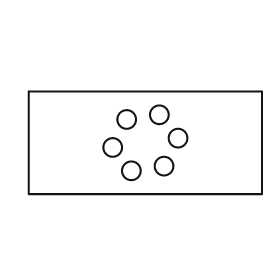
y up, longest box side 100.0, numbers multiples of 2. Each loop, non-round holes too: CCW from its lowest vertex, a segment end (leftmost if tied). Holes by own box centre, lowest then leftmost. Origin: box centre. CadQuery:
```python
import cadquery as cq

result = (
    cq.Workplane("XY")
    .moveTo(-50.0, -22.0)
    .lineTo(50.0, -22.0)
    .lineTo(50.0, 22.0)
    .lineTo(-50.0, 22.0)
    .close()
    .moveTo(-6.0, -12.0)
    .circle(4.0)
    .moveTo(8.0, -10.0)
    .circle(4.0)
    .moveTo(-14.0, -2.0)
    .circle(4.0)
    .moveTo(14.0, 2.0)
    .circle(4.0)
    .moveTo(-8.0, 10.0)
    .circle(4.0)
    .moveTo(6.0, 12.0)
    .circle(4.0)
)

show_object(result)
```